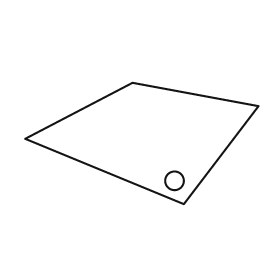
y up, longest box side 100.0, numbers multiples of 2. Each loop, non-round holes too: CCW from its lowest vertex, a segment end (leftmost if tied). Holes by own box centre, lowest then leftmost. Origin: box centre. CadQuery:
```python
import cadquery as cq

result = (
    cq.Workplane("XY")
    .moveTo(18.0, -26.0)
    .lineTo(50.0, 16.0)
    .lineTo(-4.0, 26.0)
    .lineTo(-50.0, 2.0)
    .close()
    .moveTo(14.0, -16.0)
    .circle(4.0)
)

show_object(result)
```